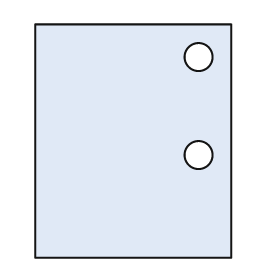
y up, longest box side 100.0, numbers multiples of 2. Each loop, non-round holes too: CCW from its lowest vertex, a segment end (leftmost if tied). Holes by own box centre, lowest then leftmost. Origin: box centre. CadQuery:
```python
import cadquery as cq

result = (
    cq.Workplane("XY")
    .moveTo(-42.0, -50.0)
    .lineTo(42.0, -50.0)
    .lineTo(42.0, 50.0)
    .lineTo(-42.0, 50.0)
    .close()
    .moveTo(28.0, -6.0)
    .circle(6.0)
    .moveTo(28.0, 36.0)
    .circle(6.0)
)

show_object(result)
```